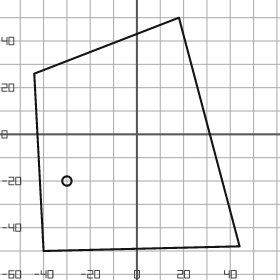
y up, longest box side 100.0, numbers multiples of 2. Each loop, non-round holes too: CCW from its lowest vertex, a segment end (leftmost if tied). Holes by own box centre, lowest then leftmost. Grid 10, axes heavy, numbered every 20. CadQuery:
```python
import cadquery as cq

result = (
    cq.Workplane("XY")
    .moveTo(-40.0, -50.0)
    .lineTo(44.0, -48.0)
    .lineTo(18.0, 50.0)
    .lineTo(-44.0, 26.0)
    .close()
    .moveTo(-30.0, -20.0)
    .circle(2.0)
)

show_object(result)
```